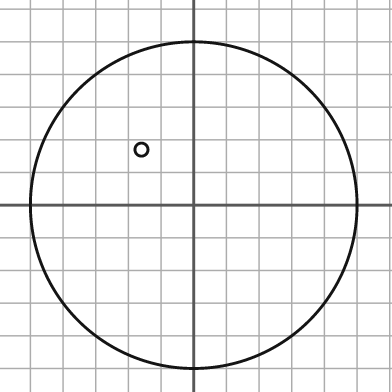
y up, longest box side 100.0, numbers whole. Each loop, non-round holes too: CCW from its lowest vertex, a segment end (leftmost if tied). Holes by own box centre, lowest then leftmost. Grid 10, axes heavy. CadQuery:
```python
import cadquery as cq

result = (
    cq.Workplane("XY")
    .moveTo(0.0, 0.0)
    .circle(50.0)
    .moveTo(-16.0, 17.0)
    .circle(2.0)
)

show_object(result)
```